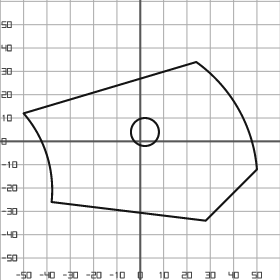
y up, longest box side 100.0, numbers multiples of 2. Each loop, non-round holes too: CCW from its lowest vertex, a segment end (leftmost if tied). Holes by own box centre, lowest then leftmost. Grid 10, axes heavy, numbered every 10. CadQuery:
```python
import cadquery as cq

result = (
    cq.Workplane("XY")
    .moveTo(28.0, -34.0)
    .lineTo(50.0, -12.0)
    .threePointArc((42.0, 14.0), (24.0, 34.0))
    .lineTo(-50.0, 12.0)
    .threePointArc((-40.0, -6.0), (-38.0, -26.0))
    .close()
    .moveTo(2.0, 4.0)
    .circle(6.0)
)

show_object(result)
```